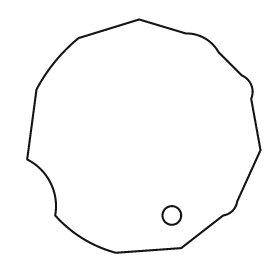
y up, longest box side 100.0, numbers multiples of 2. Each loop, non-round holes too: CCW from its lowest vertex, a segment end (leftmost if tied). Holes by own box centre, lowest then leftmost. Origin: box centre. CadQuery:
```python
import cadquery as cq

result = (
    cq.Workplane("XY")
    .moveTo(-12.0, -50.0)
    .lineTo(16.0, -48.0)
    .lineTo(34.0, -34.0)
    .threePointArc((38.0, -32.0), (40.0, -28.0))
    .lineTo(50.0, -6.0)
    .lineTo(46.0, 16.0)
    .threePointArc((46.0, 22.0), (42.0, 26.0))
    .lineTo(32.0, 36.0)
    .threePointArc((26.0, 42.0), (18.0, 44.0))
    .lineTo(-2.0, 50.0)
    .lineTo(-28.0, 42.0)
    .threePointArc((-38.0, 32.0), (-46.0, 20.0))
    .lineTo(-50.0, -10.0)
    .threePointArc((-40.0, -20.0), (-38.0, -34.0))
    .threePointArc((-26.0, -44.0), (-12.0, -50.0))
    .close()
    .moveTo(12.0, -34.0)
    .circle(4.0)
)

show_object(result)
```